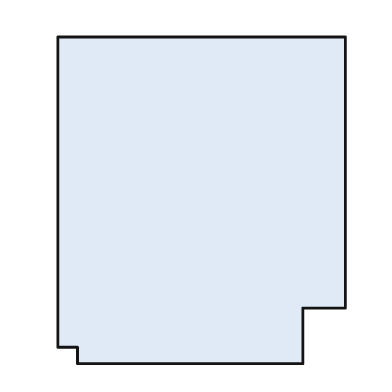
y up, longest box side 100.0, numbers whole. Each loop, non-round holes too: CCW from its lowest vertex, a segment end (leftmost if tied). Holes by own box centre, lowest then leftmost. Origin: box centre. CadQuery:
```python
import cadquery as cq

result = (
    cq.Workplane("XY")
    .moveTo(-38.0, -50.0)
    .lineTo(31.0, -50.0)
    .lineTo(31.0, -33.0)
    .lineTo(44.0, -33.0)
    .lineTo(44.0, 50.0)
    .lineTo(-44.0, 50.0)
    .lineTo(-44.0, -45.0)
    .lineTo(-38.0, -45.0)
    .close()
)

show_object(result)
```